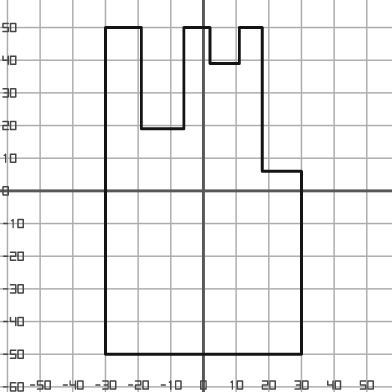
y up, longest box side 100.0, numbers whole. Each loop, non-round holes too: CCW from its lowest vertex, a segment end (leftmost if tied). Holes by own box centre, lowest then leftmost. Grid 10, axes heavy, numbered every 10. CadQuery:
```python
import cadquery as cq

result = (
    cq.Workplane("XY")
    .moveTo(-30.0, -50.0)
    .lineTo(30.0, -50.0)
    .lineTo(30.0, 6.0)
    .lineTo(18.0, 6.0)
    .lineTo(18.0, 50.0)
    .lineTo(11.0, 50.0)
    .lineTo(11.0, 39.0)
    .lineTo(2.0, 39.0)
    .lineTo(2.0, 50.0)
    .lineTo(-6.0, 50.0)
    .lineTo(-6.0, 19.0)
    .lineTo(-19.0, 19.0)
    .lineTo(-19.0, 50.0)
    .lineTo(-30.0, 50.0)
    .close()
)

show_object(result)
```